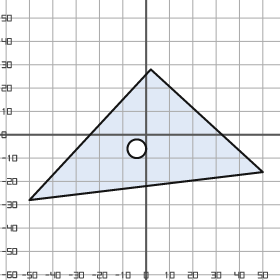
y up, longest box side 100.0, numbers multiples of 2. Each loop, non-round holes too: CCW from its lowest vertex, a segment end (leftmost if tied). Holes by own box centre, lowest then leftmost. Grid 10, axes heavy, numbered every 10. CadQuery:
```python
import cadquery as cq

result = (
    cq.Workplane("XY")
    .moveTo(-50.0, -28.0)
    .lineTo(50.0, -16.0)
    .lineTo(2.0, 28.0)
    .close()
    .moveTo(-4.0, -6.0)
    .circle(4.0)
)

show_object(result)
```